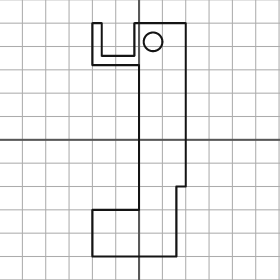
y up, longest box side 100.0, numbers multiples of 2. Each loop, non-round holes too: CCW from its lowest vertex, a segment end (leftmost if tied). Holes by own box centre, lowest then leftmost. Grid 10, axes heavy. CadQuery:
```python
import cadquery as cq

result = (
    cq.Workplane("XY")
    .moveTo(-20.0, -50.0)
    .lineTo(16.0, -50.0)
    .lineTo(16.0, -20.0)
    .lineTo(20.0, -20.0)
    .lineTo(20.0, 50.0)
    .lineTo(-2.0, 50.0)
    .lineTo(-2.0, 36.0)
    .lineTo(-16.0, 36.0)
    .lineTo(-16.0, 50.0)
    .lineTo(-20.0, 50.0)
    .lineTo(-20.0, 32.0)
    .lineTo(0.0, 32.0)
    .lineTo(0.0, -30.0)
    .lineTo(-20.0, -30.0)
    .close()
    .moveTo(6.0, 42.0)
    .circle(4.0)
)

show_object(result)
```